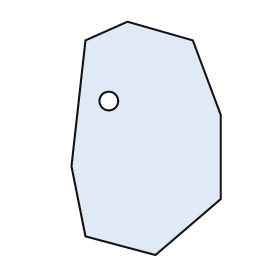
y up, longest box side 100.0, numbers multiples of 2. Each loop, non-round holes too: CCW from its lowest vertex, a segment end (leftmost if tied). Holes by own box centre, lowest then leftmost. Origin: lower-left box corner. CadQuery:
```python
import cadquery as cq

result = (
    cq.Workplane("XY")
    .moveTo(36.0, 0.0)
    .lineTo(64.0, 24.0)
    .lineTo(64.0, 60.0)
    .lineTo(52.0, 92.0)
    .lineTo(24.0, 100.0)
    .lineTo(6.0, 92.0)
    .lineTo(0.0, 38.0)
    .lineTo(6.0, 8.0)
    .close()
    .moveTo(16.0, 66.0)
    .circle(4.0)
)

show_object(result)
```